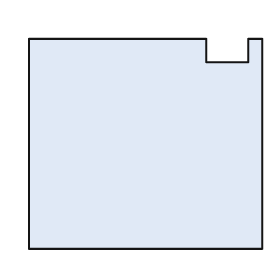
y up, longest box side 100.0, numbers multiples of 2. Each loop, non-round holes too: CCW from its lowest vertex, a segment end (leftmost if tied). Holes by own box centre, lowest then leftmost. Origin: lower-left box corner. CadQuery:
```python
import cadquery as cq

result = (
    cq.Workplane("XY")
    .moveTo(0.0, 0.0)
    .lineTo(100.0, 0.0)
    .lineTo(100.0, 90.0)
    .lineTo(94.0, 90.0)
    .lineTo(94.0, 80.0)
    .lineTo(76.0, 80.0)
    .lineTo(76.0, 90.0)
    .lineTo(0.0, 90.0)
    .close()
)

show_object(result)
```